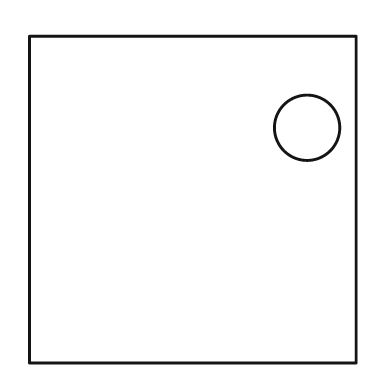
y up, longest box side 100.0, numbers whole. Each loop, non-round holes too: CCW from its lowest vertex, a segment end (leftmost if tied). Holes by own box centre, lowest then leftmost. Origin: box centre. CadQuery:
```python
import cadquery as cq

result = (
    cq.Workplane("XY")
    .moveTo(-50.0, -50.0)
    .lineTo(50.0, -50.0)
    .lineTo(50.0, 50.0)
    .lineTo(-50.0, 50.0)
    .close()
    .moveTo(35.0, 22.0)
    .circle(10.0)
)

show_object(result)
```